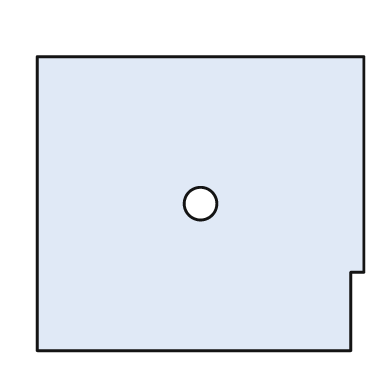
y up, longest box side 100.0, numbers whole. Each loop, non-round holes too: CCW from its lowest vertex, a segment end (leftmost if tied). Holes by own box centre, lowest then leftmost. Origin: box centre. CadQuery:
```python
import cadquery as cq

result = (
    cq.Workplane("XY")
    .moveTo(-50.0, -45.0)
    .lineTo(46.0, -45.0)
    .lineTo(46.0, -21.0)
    .lineTo(50.0, -21.0)
    .lineTo(50.0, 45.0)
    .lineTo(-50.0, 45.0)
    .close()
    .moveTo(0.0, 0.0)
    .circle(5.0)
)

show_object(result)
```